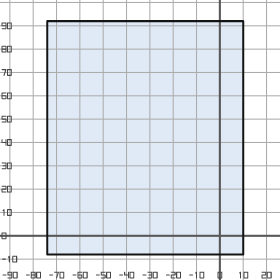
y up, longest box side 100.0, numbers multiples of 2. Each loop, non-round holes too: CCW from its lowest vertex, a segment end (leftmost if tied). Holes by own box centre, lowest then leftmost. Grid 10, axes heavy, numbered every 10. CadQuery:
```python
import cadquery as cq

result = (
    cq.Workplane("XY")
    .moveTo(-74.0, -8.0)
    .lineTo(10.0, -8.0)
    .lineTo(10.0, 92.0)
    .lineTo(-74.0, 92.0)
    .close()
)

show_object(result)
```